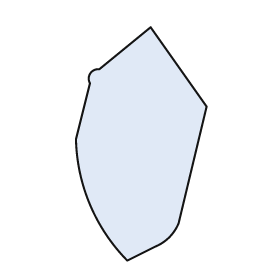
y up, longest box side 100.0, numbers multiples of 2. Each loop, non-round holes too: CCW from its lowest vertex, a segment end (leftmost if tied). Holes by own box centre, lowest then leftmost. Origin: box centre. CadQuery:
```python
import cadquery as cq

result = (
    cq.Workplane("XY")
    .moveTo(-6.0, -50.0)
    .lineTo(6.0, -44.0)
    .threePointArc((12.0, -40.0), (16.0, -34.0))
    .lineTo(28.0, 16.0)
    .lineTo(4.0, 50.0)
    .lineTo(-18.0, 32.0)
    .threePointArc((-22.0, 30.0), (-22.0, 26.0))
    .lineTo(-28.0, 2.0)
    .threePointArc((-22.0, -26.0), (-6.0, -50.0))
    .close()
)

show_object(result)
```